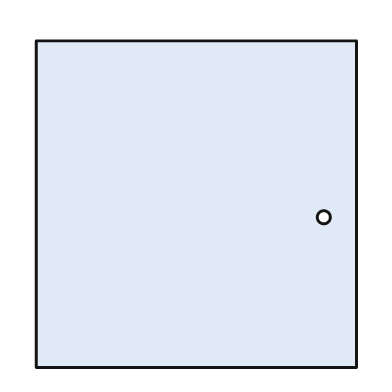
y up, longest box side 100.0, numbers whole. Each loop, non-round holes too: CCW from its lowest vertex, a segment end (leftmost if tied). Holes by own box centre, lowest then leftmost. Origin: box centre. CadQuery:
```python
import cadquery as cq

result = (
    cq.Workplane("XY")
    .moveTo(-49.0, -50.0)
    .lineTo(49.0, -50.0)
    .lineTo(49.0, 50.0)
    .lineTo(-49.0, 50.0)
    .close()
    .moveTo(39.0, -4.0)
    .circle(2.0)
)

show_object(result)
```